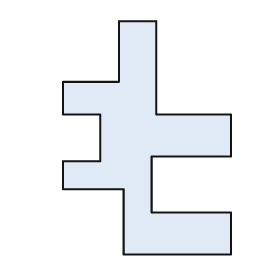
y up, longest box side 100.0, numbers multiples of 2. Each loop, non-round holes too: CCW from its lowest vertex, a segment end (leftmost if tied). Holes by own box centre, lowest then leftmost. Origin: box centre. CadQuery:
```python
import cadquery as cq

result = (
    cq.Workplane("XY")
    .moveTo(-10.0, -50.0)
    .lineTo(36.0, -50.0)
    .lineTo(36.0, -32.0)
    .lineTo(2.0, -32.0)
    .lineTo(2.0, -8.0)
    .lineTo(36.0, -8.0)
    .lineTo(36.0, 10.0)
    .lineTo(4.0, 10.0)
    .lineTo(4.0, 50.0)
    .lineTo(-12.0, 50.0)
    .lineTo(-12.0, 24.0)
    .lineTo(-36.0, 24.0)
    .lineTo(-36.0, 10.0)
    .lineTo(-20.0, 10.0)
    .lineTo(-20.0, -10.0)
    .lineTo(-36.0, -10.0)
    .lineTo(-36.0, -22.0)
    .lineTo(-10.0, -22.0)
    .close()
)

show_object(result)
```